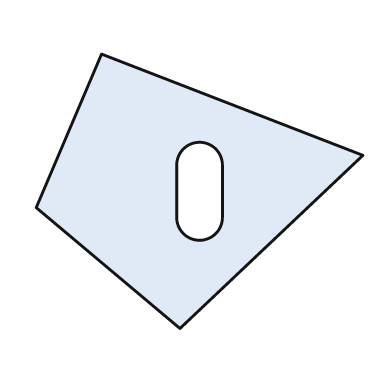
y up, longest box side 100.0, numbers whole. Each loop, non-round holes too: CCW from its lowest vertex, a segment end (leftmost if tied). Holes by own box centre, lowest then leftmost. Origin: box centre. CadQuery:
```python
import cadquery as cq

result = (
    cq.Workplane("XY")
    .moveTo(-6.0, -42.0)
    .lineTo(50.0, 11.0)
    .lineTo(-30.0, 42.0)
    .lineTo(-50.0, -5.0)
    .close()
    .moveTo(-7.0, -8.0)
    .threePointArc((0.0, -15.0), (7.0, -8.0))
    .lineTo(7.0, 8.0)
    .threePointArc((0.0, 15.0), (-7.0, 8.0))
    .close()
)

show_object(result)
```